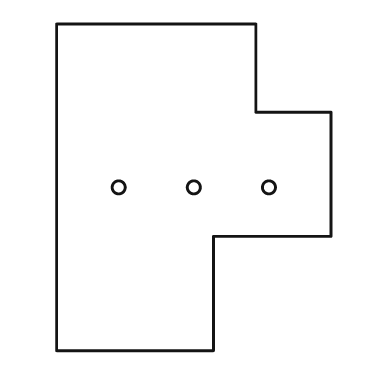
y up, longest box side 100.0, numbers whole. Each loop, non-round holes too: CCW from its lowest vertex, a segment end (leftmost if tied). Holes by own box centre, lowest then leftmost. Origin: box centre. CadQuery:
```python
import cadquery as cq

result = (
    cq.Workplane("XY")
    .moveTo(-42.0, -50.0)
    .lineTo(6.0, -50.0)
    .lineTo(6.0, -15.0)
    .lineTo(42.0, -15.0)
    .lineTo(42.0, 23.0)
    .lineTo(19.0, 23.0)
    .lineTo(19.0, 50.0)
    .lineTo(-42.0, 50.0)
    .close()
    .moveTo(-23.0, 0.0)
    .circle(2.0)
    .moveTo(0.0, 0.0)
    .circle(2.0)
    .moveTo(23.0, 0.0)
    .circle(2.0)
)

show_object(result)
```